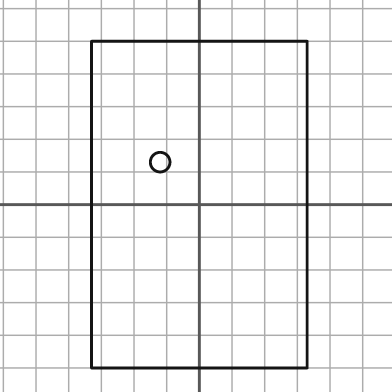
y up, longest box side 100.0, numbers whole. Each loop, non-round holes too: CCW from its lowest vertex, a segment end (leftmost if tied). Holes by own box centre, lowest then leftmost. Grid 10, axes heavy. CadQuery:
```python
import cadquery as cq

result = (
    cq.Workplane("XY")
    .moveTo(-33.0, -50.0)
    .lineTo(33.0, -50.0)
    .lineTo(33.0, 50.0)
    .lineTo(-33.0, 50.0)
    .close()
    .moveTo(-12.0, 13.0)
    .circle(3.0)
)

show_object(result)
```